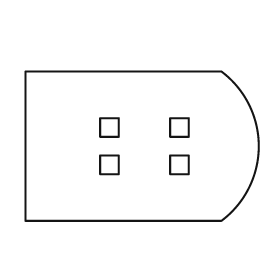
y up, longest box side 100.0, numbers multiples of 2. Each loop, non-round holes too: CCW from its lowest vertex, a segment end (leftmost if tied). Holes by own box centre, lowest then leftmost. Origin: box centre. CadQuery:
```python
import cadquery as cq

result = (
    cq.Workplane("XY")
    .moveTo(-50.0, -32.0)
    .lineTo(34.0, -32.0)
    .threePointArc((50.0, 0.0), (34.0, 32.0))
    .lineTo(-50.0, 32.0)
    .close()
    .moveTo(-18.0, -12.0)
    .lineTo(-10.0, -12.0)
    .lineTo(-10.0, -4.0)
    .lineTo(-18.0, -4.0)
    .close()
    .moveTo(12.0, -12.0)
    .lineTo(20.0, -12.0)
    .lineTo(20.0, -4.0)
    .lineTo(12.0, -4.0)
    .close()
    .moveTo(-18.0, 4.0)
    .lineTo(-10.0, 4.0)
    .lineTo(-10.0, 12.0)
    .lineTo(-18.0, 12.0)
    .close()
    .moveTo(12.0, 4.0)
    .lineTo(20.0, 4.0)
    .lineTo(20.0, 12.0)
    .lineTo(12.0, 12.0)
    .close()
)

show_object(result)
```